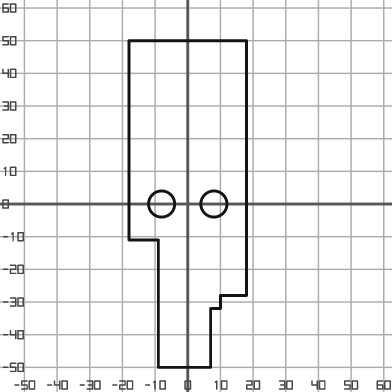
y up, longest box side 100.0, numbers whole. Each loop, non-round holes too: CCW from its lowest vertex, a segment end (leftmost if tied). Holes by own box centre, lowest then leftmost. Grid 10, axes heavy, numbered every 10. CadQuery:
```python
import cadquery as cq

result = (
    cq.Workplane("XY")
    .moveTo(-9.0, -50.0)
    .lineTo(7.0, -50.0)
    .lineTo(7.0, -32.0)
    .lineTo(10.0, -32.0)
    .lineTo(10.0, -28.0)
    .lineTo(18.0, -28.0)
    .lineTo(18.0, 50.0)
    .lineTo(-18.0, 50.0)
    .lineTo(-18.0, -11.0)
    .lineTo(-9.0, -11.0)
    .close()
    .moveTo(-8.0, 0.0)
    .circle(4.0)
    .moveTo(8.0, 0.0)
    .circle(4.0)
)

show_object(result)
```